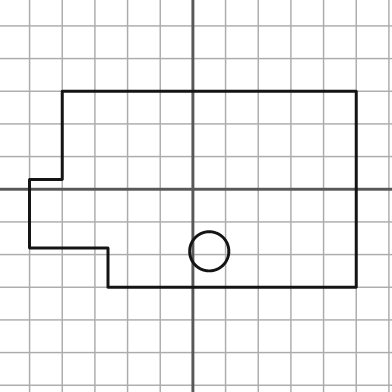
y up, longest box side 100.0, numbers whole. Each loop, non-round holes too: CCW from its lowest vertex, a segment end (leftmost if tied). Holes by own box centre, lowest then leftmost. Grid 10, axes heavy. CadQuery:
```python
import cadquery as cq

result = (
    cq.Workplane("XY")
    .moveTo(-26.0, -30.0)
    .lineTo(50.0, -30.0)
    .lineTo(50.0, 30.0)
    .lineTo(-40.0, 30.0)
    .lineTo(-40.0, 3.0)
    .lineTo(-50.0, 3.0)
    .lineTo(-50.0, -18.0)
    .lineTo(-26.0, -18.0)
    .close()
    .moveTo(5.0, -19.0)
    .circle(6.0)
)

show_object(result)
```